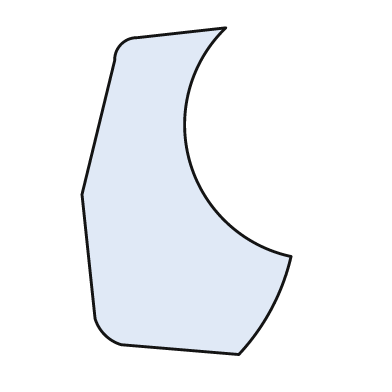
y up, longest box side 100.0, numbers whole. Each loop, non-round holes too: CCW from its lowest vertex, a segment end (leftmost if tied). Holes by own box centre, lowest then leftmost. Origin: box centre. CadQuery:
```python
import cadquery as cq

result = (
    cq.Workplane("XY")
    .moveTo(16.0, -50.0)
    .threePointArc((26.0, -36.0), (32.0, -20.0))
    .threePointArc((1.0, 9.0), (12.0, 50.0))
    .lineTo(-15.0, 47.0)
    .threePointArc((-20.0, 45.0), (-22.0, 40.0))
    .lineTo(-32.0, -1.0)
    .lineTo(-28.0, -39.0)
    .threePointArc((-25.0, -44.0), (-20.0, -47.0))
    .close()
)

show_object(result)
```